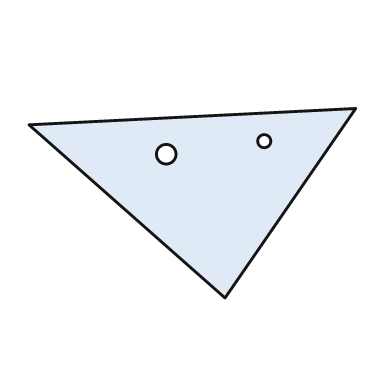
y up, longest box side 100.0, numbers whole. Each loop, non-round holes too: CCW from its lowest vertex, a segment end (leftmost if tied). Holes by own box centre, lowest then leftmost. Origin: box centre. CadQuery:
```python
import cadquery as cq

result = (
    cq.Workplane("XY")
    .moveTo(10.0, -29.0)
    .lineTo(50.0, 29.0)
    .lineTo(-50.0, 24.0)
    .close()
    .moveTo(-8.0, 15.0)
    .circle(3.0)
    .moveTo(22.0, 19.0)
    .circle(2.0)
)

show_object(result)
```